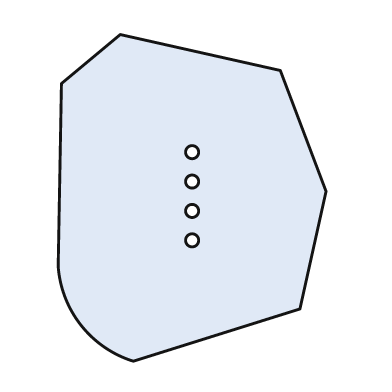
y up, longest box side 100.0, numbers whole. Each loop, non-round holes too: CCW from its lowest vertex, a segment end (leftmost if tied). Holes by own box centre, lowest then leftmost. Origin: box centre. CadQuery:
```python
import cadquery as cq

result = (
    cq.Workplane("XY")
    .moveTo(-18.0, -50.0)
    .lineTo(33.0, -34.0)
    .lineTo(41.0, 2.0)
    .lineTo(27.0, 39.0)
    .lineTo(-22.0, 50.0)
    .lineTo(-40.0, 35.0)
    .lineTo(-41.0, -21.0)
    .threePointArc((-34.0, -39.0), (-18.0, -50.0))
    .close()
    .moveTo(0.0, -13.0)
    .circle(2.0)
    .moveTo(0.0, -4.0)
    .circle(2.0)
    .moveTo(0.0, 5.0)
    .circle(2.0)
    .moveTo(0.0, 14.0)
    .circle(2.0)
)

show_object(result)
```